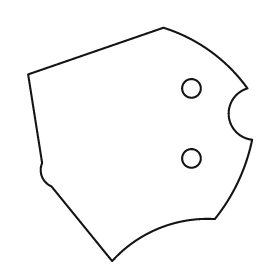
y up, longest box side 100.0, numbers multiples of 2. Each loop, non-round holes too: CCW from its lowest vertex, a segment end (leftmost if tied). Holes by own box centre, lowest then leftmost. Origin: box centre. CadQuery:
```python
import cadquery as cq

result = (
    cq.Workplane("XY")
    .moveTo(-12.0, -50.0)
    .threePointArc((8.0, -36.0), (32.0, -32.0))
    .threePointArc((42.0, -16.0), (48.0, 2.0))
    .threePointArc((38.0, 12.0), (46.0, 24.0))
    .threePointArc((30.0, 40.0), (10.0, 50.0))
    .lineTo(-48.0, 30.0)
    .lineTo(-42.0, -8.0)
    .threePointArc((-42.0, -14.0), (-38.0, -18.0))
    .close()
    .moveTo(22.0, -6.0)
    .circle(4.0)
    .moveTo(22.0, 24.0)
    .circle(4.0)
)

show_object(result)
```